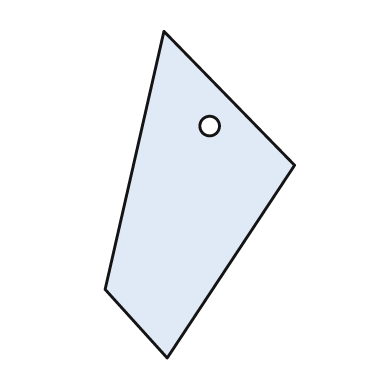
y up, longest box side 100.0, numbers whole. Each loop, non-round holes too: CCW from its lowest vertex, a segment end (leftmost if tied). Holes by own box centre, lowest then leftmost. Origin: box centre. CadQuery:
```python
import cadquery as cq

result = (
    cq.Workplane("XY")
    .moveTo(-10.0, -50.0)
    .lineTo(29.0, 9.0)
    .lineTo(-11.0, 50.0)
    .lineTo(-29.0, -29.0)
    .close()
    .moveTo(3.0, 21.0)
    .circle(3.0)
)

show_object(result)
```